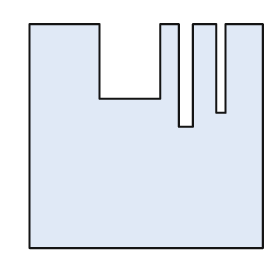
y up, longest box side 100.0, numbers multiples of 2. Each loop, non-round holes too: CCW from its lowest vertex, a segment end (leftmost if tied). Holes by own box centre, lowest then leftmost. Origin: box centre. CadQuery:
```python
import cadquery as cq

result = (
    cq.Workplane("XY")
    .moveTo(-50.0, -48.0)
    .lineTo(50.0, -48.0)
    .lineTo(50.0, 48.0)
    .lineTo(34.0, 48.0)
    .lineTo(34.0, 10.0)
    .lineTo(30.0, 10.0)
    .lineTo(30.0, 48.0)
    .lineTo(20.0, 48.0)
    .lineTo(20.0, 4.0)
    .lineTo(14.0, 4.0)
    .lineTo(14.0, 48.0)
    .lineTo(6.0, 48.0)
    .lineTo(6.0, 16.0)
    .lineTo(-20.0, 16.0)
    .lineTo(-20.0, 48.0)
    .lineTo(-50.0, 48.0)
    .close()
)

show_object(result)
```